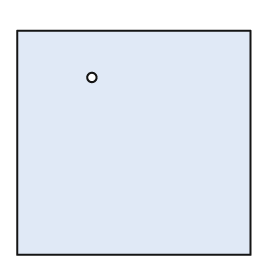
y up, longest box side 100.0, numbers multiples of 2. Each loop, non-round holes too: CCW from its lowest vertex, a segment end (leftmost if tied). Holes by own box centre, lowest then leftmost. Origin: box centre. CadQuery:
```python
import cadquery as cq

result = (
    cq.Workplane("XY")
    .moveTo(-50.0, -48.0)
    .lineTo(50.0, -48.0)
    .lineTo(50.0, 48.0)
    .lineTo(-50.0, 48.0)
    .close()
    .moveTo(-18.0, 28.0)
    .circle(2.0)
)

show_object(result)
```